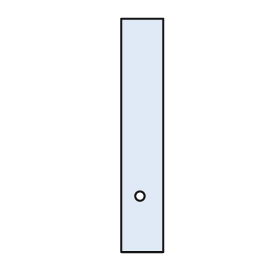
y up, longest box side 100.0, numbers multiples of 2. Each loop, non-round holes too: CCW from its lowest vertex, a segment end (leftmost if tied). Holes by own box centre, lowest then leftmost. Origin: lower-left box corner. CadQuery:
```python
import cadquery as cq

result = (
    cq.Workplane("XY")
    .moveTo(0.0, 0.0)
    .lineTo(18.0, 0.0)
    .lineTo(18.0, 100.0)
    .lineTo(0.0, 100.0)
    .close()
    .moveTo(8.0, 24.0)
    .circle(2.0)
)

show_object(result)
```